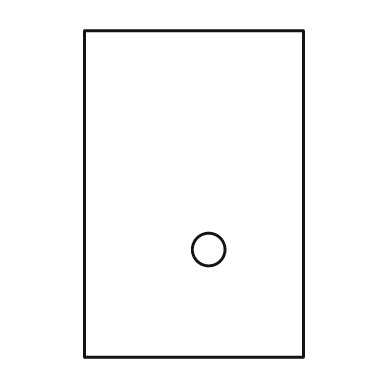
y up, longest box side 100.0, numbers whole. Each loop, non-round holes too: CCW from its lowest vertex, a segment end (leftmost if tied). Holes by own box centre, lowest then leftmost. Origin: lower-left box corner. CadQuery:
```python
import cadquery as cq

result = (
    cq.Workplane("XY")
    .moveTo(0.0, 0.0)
    .lineTo(67.0, 0.0)
    .lineTo(67.0, 100.0)
    .lineTo(0.0, 100.0)
    .close()
    .moveTo(38.0, 33.0)
    .circle(5.0)
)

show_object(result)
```